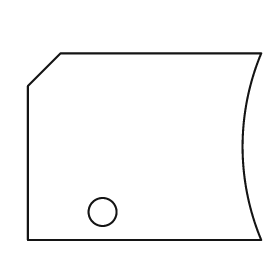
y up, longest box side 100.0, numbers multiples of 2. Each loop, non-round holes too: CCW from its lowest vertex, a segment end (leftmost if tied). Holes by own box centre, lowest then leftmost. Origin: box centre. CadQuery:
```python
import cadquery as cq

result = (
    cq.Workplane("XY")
    .moveTo(-50.0, -40.0)
    .lineTo(50.0, -40.0)
    .threePointArc((42.0, 0.0), (50.0, 40.0))
    .lineTo(-36.0, 40.0)
    .lineTo(-50.0, 26.0)
    .close()
    .moveTo(-18.0, -28.0)
    .circle(6.0)
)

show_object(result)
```